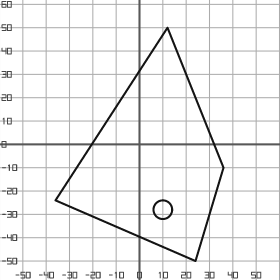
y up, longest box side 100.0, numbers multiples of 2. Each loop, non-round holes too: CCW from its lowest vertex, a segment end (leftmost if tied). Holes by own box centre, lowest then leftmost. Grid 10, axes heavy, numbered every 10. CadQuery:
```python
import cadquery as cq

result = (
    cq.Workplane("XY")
    .moveTo(24.0, -50.0)
    .lineTo(36.0, -10.0)
    .lineTo(12.0, 50.0)
    .lineTo(-36.0, -24.0)
    .close()
    .moveTo(10.0, -28.0)
    .circle(4.0)
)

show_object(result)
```